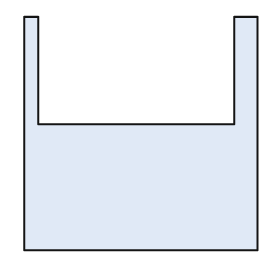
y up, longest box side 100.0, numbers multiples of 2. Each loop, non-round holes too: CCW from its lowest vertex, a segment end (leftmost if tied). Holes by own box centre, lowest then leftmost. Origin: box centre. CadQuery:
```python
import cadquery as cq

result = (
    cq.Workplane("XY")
    .moveTo(-50.0, -50.0)
    .lineTo(50.0, -50.0)
    .lineTo(50.0, 50.0)
    .lineTo(40.0, 50.0)
    .lineTo(40.0, 4.0)
    .lineTo(-44.0, 4.0)
    .lineTo(-44.0, 50.0)
    .lineTo(-50.0, 50.0)
    .close()
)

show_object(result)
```